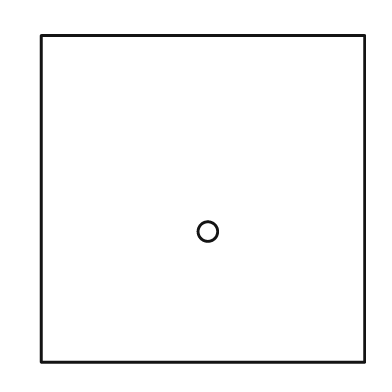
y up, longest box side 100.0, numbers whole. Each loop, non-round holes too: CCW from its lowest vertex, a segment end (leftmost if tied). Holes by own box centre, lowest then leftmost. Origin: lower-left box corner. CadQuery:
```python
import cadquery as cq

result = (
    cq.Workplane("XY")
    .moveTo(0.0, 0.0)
    .lineTo(99.0, 0.0)
    .lineTo(99.0, 100.0)
    .lineTo(0.0, 100.0)
    .close()
    .moveTo(51.0, 40.0)
    .circle(3.0)
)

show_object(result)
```